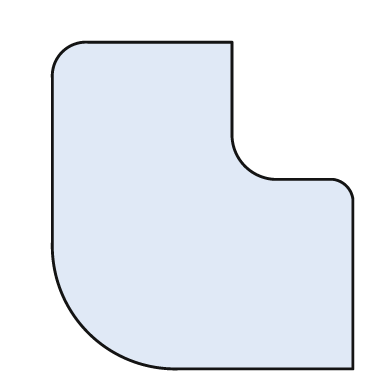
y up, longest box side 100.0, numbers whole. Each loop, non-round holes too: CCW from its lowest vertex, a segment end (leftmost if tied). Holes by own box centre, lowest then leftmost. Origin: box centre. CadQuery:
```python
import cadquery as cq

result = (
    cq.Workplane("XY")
    .moveTo(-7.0, -50.0)
    .lineTo(46.0, -50.0)
    .lineTo(46.0, 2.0)
    .threePointArc((44.0, 6.0), (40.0, 8.0))
    .lineTo(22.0, 8.0)
    .threePointArc((13.0, 12.0), (9.0, 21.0))
    .lineTo(9.0, 50.0)
    .lineTo(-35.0, 50.0)
    .threePointArc((-43.0, 47.0), (-46.0, 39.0))
    .lineTo(-46.0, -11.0)
    .threePointArc((-35.0, -39.0), (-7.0, -50.0))
    .close()
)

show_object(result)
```